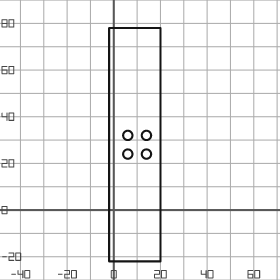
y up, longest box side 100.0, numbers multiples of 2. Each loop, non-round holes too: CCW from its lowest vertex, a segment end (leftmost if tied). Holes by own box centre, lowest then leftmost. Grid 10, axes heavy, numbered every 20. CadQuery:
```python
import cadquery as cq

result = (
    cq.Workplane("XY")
    .moveTo(-2.0, -22.0)
    .lineTo(20.0, -22.0)
    .lineTo(20.0, 78.0)
    .lineTo(-2.0, 78.0)
    .close()
    .moveTo(6.0, 24.0)
    .circle(2.0)
    .moveTo(14.0, 24.0)
    .circle(2.0)
    .moveTo(6.0, 32.0)
    .circle(2.0)
    .moveTo(14.0, 32.0)
    .circle(2.0)
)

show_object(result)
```